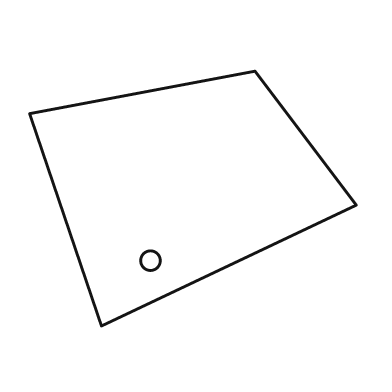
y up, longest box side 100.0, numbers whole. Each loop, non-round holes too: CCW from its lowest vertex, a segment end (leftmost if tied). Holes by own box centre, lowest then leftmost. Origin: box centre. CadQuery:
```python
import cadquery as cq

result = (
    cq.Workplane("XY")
    .moveTo(-28.0, -39.0)
    .lineTo(50.0, -2.0)
    .lineTo(19.0, 39.0)
    .lineTo(-50.0, 26.0)
    .close()
    .moveTo(-13.0, -19.0)
    .circle(3.0)
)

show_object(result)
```